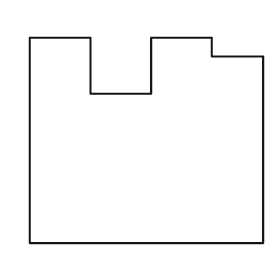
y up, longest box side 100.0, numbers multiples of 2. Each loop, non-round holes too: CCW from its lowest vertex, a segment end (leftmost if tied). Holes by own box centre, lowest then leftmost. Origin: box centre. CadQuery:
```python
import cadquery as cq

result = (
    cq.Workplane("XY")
    .moveTo(-50.0, -44.0)
    .lineTo(50.0, -44.0)
    .lineTo(50.0, 36.0)
    .lineTo(28.0, 36.0)
    .lineTo(28.0, 44.0)
    .lineTo(2.0, 44.0)
    .lineTo(2.0, 20.0)
    .lineTo(-24.0, 20.0)
    .lineTo(-24.0, 44.0)
    .lineTo(-50.0, 44.0)
    .close()
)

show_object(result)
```